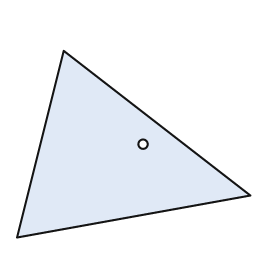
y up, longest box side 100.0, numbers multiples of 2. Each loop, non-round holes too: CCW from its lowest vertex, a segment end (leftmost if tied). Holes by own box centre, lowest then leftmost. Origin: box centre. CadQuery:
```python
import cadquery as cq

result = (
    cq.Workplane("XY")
    .moveTo(-50.0, -40.0)
    .lineTo(50.0, -22.0)
    .lineTo(-30.0, 40.0)
    .close()
    .moveTo(4.0, 0.0)
    .circle(2.0)
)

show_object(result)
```